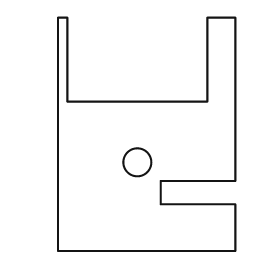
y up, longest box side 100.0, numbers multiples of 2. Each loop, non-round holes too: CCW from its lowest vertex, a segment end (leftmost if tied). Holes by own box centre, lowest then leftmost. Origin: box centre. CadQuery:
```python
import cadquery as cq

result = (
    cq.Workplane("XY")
    .moveTo(-38.0, -50.0)
    .lineTo(38.0, -50.0)
    .lineTo(38.0, -30.0)
    .lineTo(6.0, -30.0)
    .lineTo(6.0, -20.0)
    .lineTo(38.0, -20.0)
    .lineTo(38.0, 50.0)
    .lineTo(26.0, 50.0)
    .lineTo(26.0, 14.0)
    .lineTo(-34.0, 14.0)
    .lineTo(-34.0, 50.0)
    .lineTo(-38.0, 50.0)
    .close()
    .moveTo(-4.0, -12.0)
    .circle(6.0)
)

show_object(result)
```